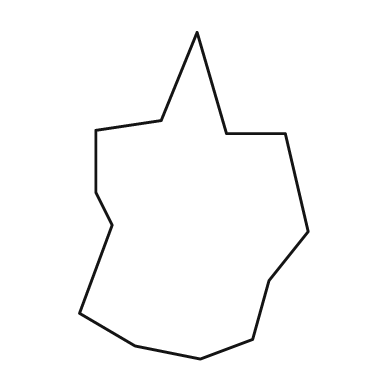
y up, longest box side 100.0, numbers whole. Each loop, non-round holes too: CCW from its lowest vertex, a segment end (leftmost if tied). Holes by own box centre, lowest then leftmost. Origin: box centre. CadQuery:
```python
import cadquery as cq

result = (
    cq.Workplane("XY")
    .moveTo(2.0, -50.0)
    .lineTo(18.0, -44.0)
    .lineTo(23.0, -26.0)
    .lineTo(35.0, -11.0)
    .lineTo(28.0, 19.0)
    .lineTo(10.0, 19.0)
    .lineTo(1.0, 50.0)
    .lineTo(-10.0, 23.0)
    .lineTo(-30.0, 20.0)
    .lineTo(-30.0, 1.0)
    .lineTo(-25.0, -9.0)
    .lineTo(-35.0, -36.0)
    .lineTo(-18.0, -46.0)
    .close()
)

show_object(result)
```